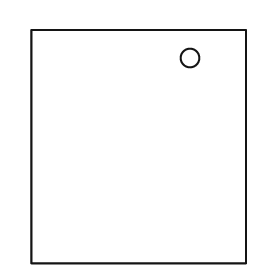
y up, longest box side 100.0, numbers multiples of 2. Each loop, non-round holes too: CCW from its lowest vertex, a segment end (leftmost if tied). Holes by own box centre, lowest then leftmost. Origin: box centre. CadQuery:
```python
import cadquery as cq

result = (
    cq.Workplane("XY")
    .moveTo(-46.0, -50.0)
    .lineTo(46.0, -50.0)
    .lineTo(46.0, 50.0)
    .lineTo(-46.0, 50.0)
    .close()
    .moveTo(22.0, 38.0)
    .circle(4.0)
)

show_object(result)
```